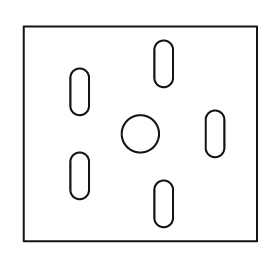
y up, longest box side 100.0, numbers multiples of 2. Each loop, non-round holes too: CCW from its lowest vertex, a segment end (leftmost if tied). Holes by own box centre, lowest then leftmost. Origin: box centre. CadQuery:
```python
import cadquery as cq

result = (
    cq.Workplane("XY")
    .moveTo(-50.0, -46.0)
    .lineTo(50.0, -46.0)
    .lineTo(50.0, 46.0)
    .lineTo(-50.0, 46.0)
    .close()
    .moveTo(6.0, -36.0)
    .threePointArc((10.0, -40.0), (14.0, -36.0))
    .lineTo(14.0, -24.0)
    .threePointArc((10.0, -20.0), (6.0, -24.0))
    .close()
    .moveTo(-30.0, -24.0)
    .threePointArc((-26.0, -28.0), (-22.0, -24.0))
    .lineTo(-22.0, -12.0)
    .threePointArc((-26.0, -8.0), (-30.0, -12.0))
    .close()
    .moveTo(0.0, 0.0)
    .circle(8.0)
    .moveTo(28.0, -6.0)
    .threePointArc((32.0, -10.0), (36.0, -6.0))
    .lineTo(36.0, 6.0)
    .threePointArc((32.0, 10.0), (28.0, 6.0))
    .close()
    .moveTo(-30.0, 12.0)
    .threePointArc((-26.0, 8.0), (-22.0, 12.0))
    .lineTo(-22.0, 24.0)
    .threePointArc((-26.0, 28.0), (-30.0, 24.0))
    .close()
    .moveTo(6.0, 24.0)
    .threePointArc((10.0, 20.0), (14.0, 24.0))
    .lineTo(14.0, 36.0)
    .threePointArc((10.0, 40.0), (6.0, 36.0))
    .close()
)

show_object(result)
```